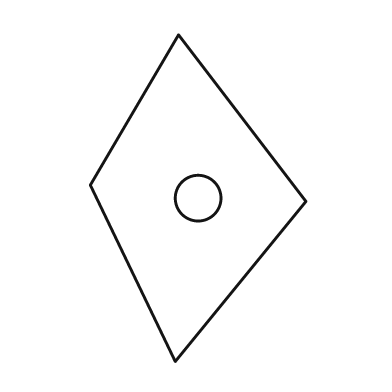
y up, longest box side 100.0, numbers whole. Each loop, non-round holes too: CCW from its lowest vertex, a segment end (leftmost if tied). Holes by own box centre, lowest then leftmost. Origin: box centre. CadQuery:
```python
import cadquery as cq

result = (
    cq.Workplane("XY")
    .moveTo(-7.0, -50.0)
    .lineTo(33.0, -1.0)
    .lineTo(-6.0, 50.0)
    .lineTo(-33.0, 4.0)
    .close()
    .moveTo(0.0, 0.0)
    .circle(7.0)
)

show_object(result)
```